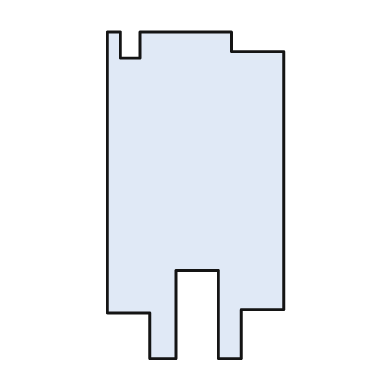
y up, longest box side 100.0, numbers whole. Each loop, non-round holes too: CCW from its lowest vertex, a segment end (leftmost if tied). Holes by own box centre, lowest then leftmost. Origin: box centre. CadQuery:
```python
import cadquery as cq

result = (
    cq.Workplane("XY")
    .moveTo(-14.0, -50.0)
    .lineTo(-6.0, -50.0)
    .lineTo(-6.0, -23.0)
    .lineTo(7.0, -23.0)
    .lineTo(7.0, -50.0)
    .lineTo(14.0, -50.0)
    .lineTo(14.0, -35.0)
    .lineTo(27.0, -35.0)
    .lineTo(27.0, 44.0)
    .lineTo(11.0, 44.0)
    .lineTo(11.0, 50.0)
    .lineTo(-17.0, 50.0)
    .lineTo(-17.0, 42.0)
    .lineTo(-23.0, 42.0)
    .lineTo(-23.0, 50.0)
    .lineTo(-27.0, 50.0)
    .lineTo(-27.0, -36.0)
    .lineTo(-14.0, -36.0)
    .close()
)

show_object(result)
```